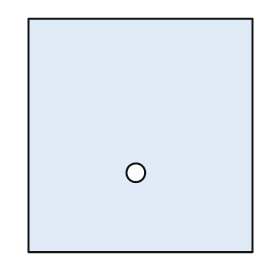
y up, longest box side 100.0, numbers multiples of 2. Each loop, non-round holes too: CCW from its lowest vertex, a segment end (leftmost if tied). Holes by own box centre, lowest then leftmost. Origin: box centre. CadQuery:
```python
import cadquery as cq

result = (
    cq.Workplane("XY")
    .moveTo(-48.0, -50.0)
    .lineTo(48.0, -50.0)
    .lineTo(48.0, 50.0)
    .lineTo(-48.0, 50.0)
    .close()
    .moveTo(-2.0, -16.0)
    .circle(4.0)
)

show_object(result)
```